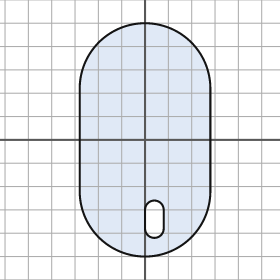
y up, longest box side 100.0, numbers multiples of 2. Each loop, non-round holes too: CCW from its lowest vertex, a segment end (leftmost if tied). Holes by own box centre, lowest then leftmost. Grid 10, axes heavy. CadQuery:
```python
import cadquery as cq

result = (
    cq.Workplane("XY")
    .moveTo(-28.0, -22.0)
    .threePointArc((0.0, -50.0), (28.0, -22.0))
    .lineTo(28.0, 22.0)
    .threePointArc((0.0, 50.0), (-28.0, 22.0))
    .close()
    .moveTo(0.0, -38.0)
    .threePointArc((4.0, -42.0), (8.0, -38.0))
    .lineTo(8.0, -30.0)
    .threePointArc((4.0, -26.0), (0.0, -30.0))
    .close()
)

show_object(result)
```